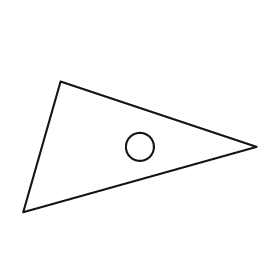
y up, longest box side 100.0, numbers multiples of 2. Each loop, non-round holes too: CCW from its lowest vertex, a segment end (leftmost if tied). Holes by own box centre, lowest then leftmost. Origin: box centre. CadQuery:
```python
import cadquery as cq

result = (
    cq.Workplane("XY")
    .moveTo(-50.0, -28.0)
    .lineTo(50.0, 0.0)
    .lineTo(-34.0, 28.0)
    .close()
    .moveTo(0.0, 0.0)
    .circle(6.0)
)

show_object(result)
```